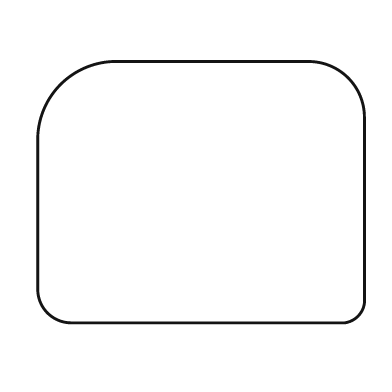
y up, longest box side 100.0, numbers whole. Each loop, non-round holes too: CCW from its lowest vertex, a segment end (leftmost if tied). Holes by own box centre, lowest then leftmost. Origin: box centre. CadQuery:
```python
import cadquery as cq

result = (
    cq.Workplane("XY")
    .moveTo(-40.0, -40.0)
    .lineTo(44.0, -40.0)
    .threePointArc((48.0, -38.0), (50.0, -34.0))
    .lineTo(50.0, 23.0)
    .threePointArc((45.0, 35.0), (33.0, 40.0))
    .lineTo(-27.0, 40.0)
    .threePointArc((-43.0, 33.0), (-50.0, 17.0))
    .lineTo(-50.0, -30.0)
    .threePointArc((-47.0, -37.0), (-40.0, -40.0))
    .close()
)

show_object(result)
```